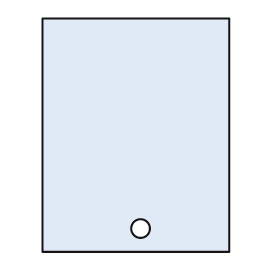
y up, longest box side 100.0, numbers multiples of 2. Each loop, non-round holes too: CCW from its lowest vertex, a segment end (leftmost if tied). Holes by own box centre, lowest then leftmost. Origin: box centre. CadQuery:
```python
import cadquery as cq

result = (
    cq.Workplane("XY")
    .moveTo(-40.0, -50.0)
    .lineTo(40.0, -50.0)
    .lineTo(40.0, 50.0)
    .lineTo(-40.0, 50.0)
    .close()
    .moveTo(2.0, -40.0)
    .circle(4.0)
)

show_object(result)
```